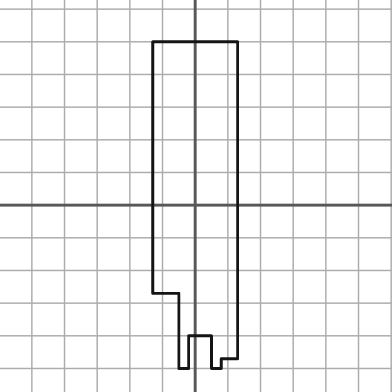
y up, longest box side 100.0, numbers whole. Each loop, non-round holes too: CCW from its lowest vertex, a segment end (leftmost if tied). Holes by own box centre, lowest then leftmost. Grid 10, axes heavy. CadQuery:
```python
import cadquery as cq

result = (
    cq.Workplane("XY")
    .moveTo(-5.0, -50.0)
    .lineTo(-2.0, -50.0)
    .lineTo(-2.0, -40.0)
    .lineTo(5.0, -40.0)
    .lineTo(5.0, -50.0)
    .lineTo(8.0, -50.0)
    .lineTo(8.0, -47.0)
    .lineTo(13.0, -47.0)
    .lineTo(13.0, 50.0)
    .lineTo(-13.0, 50.0)
    .lineTo(-13.0, -27.0)
    .lineTo(-5.0, -27.0)
    .close()
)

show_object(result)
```